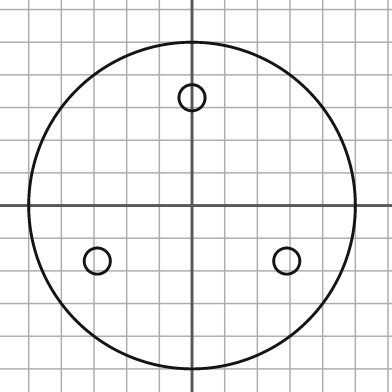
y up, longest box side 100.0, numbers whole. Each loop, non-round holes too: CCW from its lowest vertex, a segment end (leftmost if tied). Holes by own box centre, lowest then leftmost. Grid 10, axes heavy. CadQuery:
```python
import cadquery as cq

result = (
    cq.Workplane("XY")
    .moveTo(0.0, 0.0)
    .circle(50.0)
    .moveTo(-29.0, -17.0)
    .circle(4.0)
    .moveTo(29.0, -17.0)
    .circle(4.0)
    .moveTo(0.0, 33.0)
    .circle(4.0)
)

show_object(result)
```